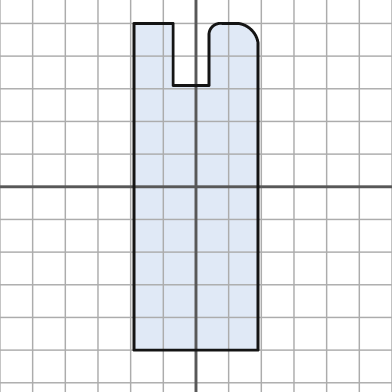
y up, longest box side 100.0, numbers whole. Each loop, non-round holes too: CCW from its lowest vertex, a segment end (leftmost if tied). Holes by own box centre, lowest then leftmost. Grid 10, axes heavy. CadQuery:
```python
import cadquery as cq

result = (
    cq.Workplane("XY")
    .moveTo(-19.0, -50.0)
    .lineTo(19.0, -50.0)
    .lineTo(19.0, 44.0)
    .threePointArc((17.0, 48.0), (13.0, 50.0))
    .lineTo(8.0, 50.0)
    .threePointArc((5.0, 49.0), (4.0, 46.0))
    .lineTo(4.0, 31.0)
    .lineTo(-7.0, 31.0)
    .lineTo(-7.0, 50.0)
    .lineTo(-19.0, 50.0)
    .close()
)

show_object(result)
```